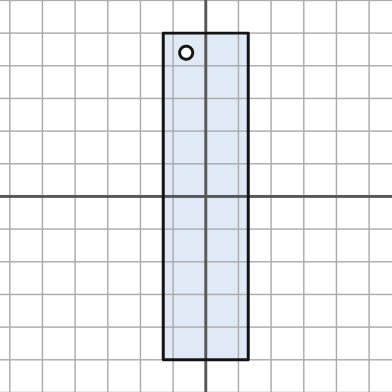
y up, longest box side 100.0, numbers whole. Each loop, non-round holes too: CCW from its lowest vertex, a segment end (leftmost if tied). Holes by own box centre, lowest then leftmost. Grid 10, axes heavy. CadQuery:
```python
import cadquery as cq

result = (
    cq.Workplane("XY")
    .moveTo(-13.0, -50.0)
    .lineTo(13.0, -50.0)
    .lineTo(13.0, 50.0)
    .lineTo(-13.0, 50.0)
    .close()
    .moveTo(-6.0, 44.0)
    .circle(2.0)
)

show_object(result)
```